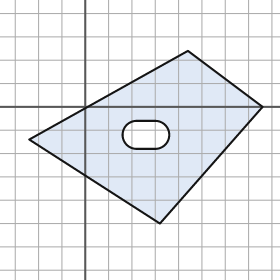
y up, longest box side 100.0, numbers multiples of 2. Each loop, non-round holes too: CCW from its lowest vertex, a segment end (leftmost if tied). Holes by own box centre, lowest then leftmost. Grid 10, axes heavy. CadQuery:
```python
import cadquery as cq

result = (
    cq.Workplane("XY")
    .moveTo(32.0, -50.0)
    .lineTo(76.0, 0.0)
    .lineTo(44.0, 24.0)
    .lineTo(-24.0, -14.0)
    .close()
    .moveTo(22.0, -18.0)
    .lineTo(30.0, -18.0)
    .threePointArc((36.0, -12.0), (30.0, -6.0))
    .lineTo(22.0, -6.0)
    .threePointArc((16.0, -12.0), (22.0, -18.0))
    .close()
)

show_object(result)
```